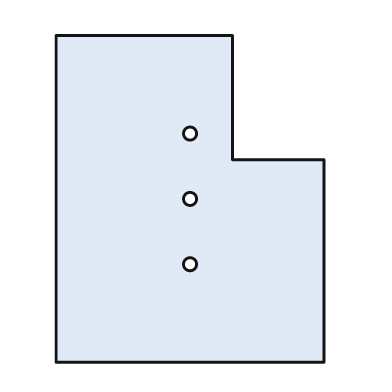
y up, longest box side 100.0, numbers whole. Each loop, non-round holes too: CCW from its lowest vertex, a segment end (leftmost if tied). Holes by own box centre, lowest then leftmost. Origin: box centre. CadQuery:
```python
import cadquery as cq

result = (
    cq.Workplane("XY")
    .moveTo(-41.0, -50.0)
    .lineTo(41.0, -50.0)
    .lineTo(41.0, 12.0)
    .lineTo(13.0, 12.0)
    .lineTo(13.0, 50.0)
    .lineTo(-41.0, 50.0)
    .close()
    .moveTo(0.0, -20.0)
    .circle(2.0)
    .moveTo(0.0, 0.0)
    .circle(2.0)
    .moveTo(0.0, 20.0)
    .circle(2.0)
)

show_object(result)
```